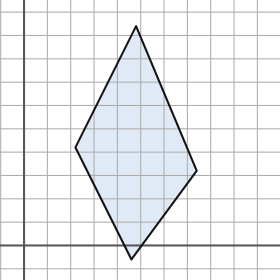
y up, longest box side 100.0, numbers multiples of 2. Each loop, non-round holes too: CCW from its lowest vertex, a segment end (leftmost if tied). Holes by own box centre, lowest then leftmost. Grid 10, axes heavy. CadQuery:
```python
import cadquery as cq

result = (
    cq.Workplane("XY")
    .moveTo(46.0, -6.0)
    .lineTo(74.0, 32.0)
    .lineTo(48.0, 94.0)
    .lineTo(22.0, 42.0)
    .close()
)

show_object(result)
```